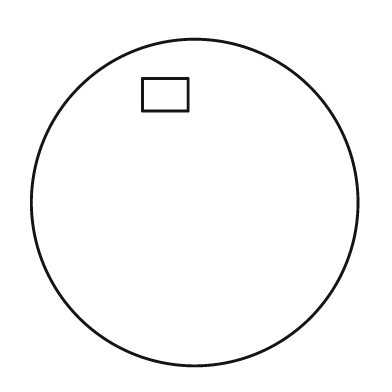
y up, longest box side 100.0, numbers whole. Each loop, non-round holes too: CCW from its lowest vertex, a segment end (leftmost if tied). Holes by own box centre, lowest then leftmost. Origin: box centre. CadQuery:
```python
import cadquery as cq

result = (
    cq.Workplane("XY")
    .moveTo(0.0, 0.0)
    .circle(50.0)
    .moveTo(-16.0, 28.0)
    .lineTo(-2.0, 28.0)
    .lineTo(-2.0, 38.0)
    .lineTo(-16.0, 38.0)
    .close()
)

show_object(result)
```